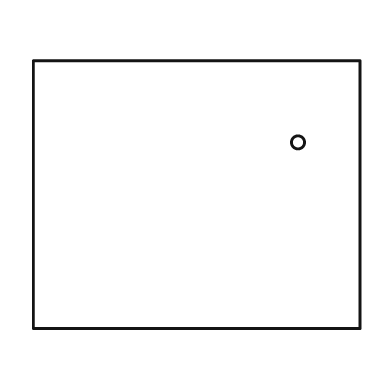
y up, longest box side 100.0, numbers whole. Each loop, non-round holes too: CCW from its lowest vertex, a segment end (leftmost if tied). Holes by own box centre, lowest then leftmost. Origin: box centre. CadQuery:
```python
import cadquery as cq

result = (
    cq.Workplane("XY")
    .moveTo(-50.0, -41.0)
    .lineTo(50.0, -41.0)
    .lineTo(50.0, 41.0)
    .lineTo(-50.0, 41.0)
    .close()
    .moveTo(31.0, 16.0)
    .circle(2.0)
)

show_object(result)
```